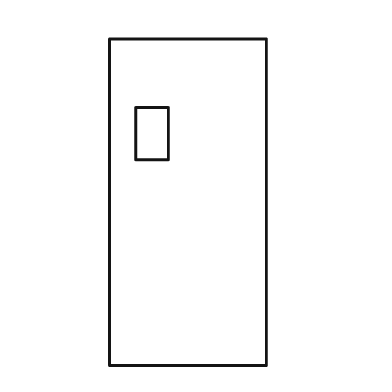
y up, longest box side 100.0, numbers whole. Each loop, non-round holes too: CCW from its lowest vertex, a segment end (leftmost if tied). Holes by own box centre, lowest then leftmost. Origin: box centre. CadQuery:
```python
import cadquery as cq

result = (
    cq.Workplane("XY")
    .moveTo(-24.0, -50.0)
    .lineTo(24.0, -50.0)
    .lineTo(24.0, 50.0)
    .lineTo(-24.0, 50.0)
    .close()
    .moveTo(-16.0, 13.0)
    .lineTo(-6.0, 13.0)
    .lineTo(-6.0, 29.0)
    .lineTo(-16.0, 29.0)
    .close()
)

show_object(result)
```